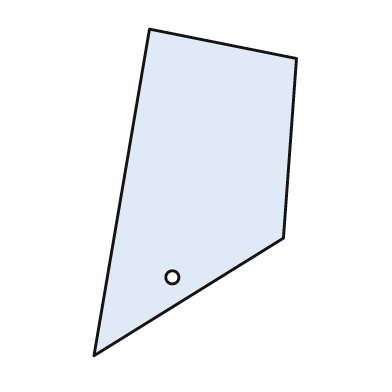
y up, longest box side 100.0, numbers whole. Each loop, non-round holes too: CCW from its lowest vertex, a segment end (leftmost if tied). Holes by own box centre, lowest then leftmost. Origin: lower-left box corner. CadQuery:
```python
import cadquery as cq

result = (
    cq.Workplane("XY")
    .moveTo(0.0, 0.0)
    .lineTo(58.0, 36.0)
    .lineTo(62.0, 91.0)
    .lineTo(17.0, 100.0)
    .close()
    .moveTo(24.0, 24.0)
    .circle(2.0)
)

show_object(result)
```